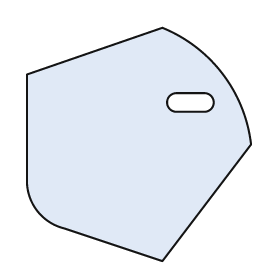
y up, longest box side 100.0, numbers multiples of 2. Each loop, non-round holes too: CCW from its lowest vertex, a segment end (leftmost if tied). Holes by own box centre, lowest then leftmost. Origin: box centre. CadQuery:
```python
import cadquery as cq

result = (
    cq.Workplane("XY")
    .moveTo(10.0, -50.0)
    .lineTo(48.0, 0.0)
    .threePointArc((36.0, 30.0), (10.0, 50.0))
    .lineTo(-48.0, 30.0)
    .lineTo(-48.0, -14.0)
    .threePointArc((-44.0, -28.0), (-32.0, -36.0))
    .close()
    .moveTo(16.0, 14.0)
    .lineTo(28.0, 14.0)
    .threePointArc((32.0, 18.0), (28.0, 22.0))
    .lineTo(16.0, 22.0)
    .threePointArc((12.0, 18.0), (16.0, 14.0))
    .close()
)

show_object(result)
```